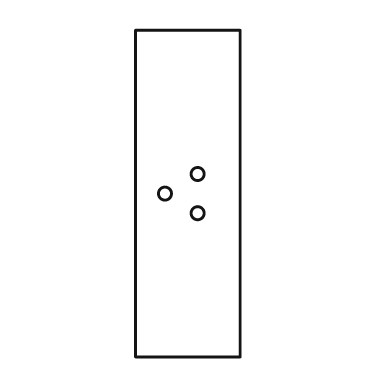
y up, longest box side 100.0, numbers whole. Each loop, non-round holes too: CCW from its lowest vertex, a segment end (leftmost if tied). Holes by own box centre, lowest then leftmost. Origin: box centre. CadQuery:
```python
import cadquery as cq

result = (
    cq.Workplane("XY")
    .moveTo(-16.0, -50.0)
    .lineTo(16.0, -50.0)
    .lineTo(16.0, 50.0)
    .lineTo(-16.0, 50.0)
    .close()
    .moveTo(3.0, -6.0)
    .circle(2.0)
    .moveTo(-7.0, 0.0)
    .circle(2.0)
    .moveTo(3.0, 6.0)
    .circle(2.0)
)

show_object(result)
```